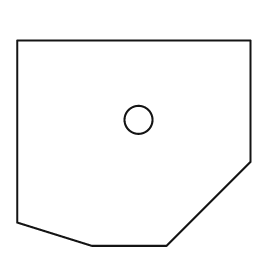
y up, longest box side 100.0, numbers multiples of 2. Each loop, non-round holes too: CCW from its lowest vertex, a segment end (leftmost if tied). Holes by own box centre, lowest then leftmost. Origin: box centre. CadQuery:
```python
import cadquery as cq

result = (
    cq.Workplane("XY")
    .moveTo(-18.0, -44.0)
    .lineTo(14.0, -44.0)
    .lineTo(50.0, -8.0)
    .lineTo(50.0, 44.0)
    .lineTo(-50.0, 44.0)
    .lineTo(-50.0, -34.0)
    .close()
    .moveTo(2.0, 10.0)
    .circle(6.0)
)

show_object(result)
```